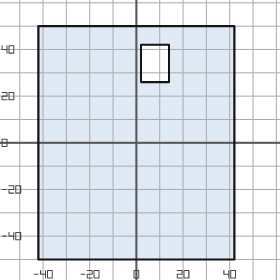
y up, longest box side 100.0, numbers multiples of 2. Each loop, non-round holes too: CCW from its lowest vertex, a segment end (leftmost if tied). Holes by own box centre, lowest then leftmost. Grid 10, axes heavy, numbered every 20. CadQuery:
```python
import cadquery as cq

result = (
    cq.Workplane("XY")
    .moveTo(-42.0, -50.0)
    .lineTo(42.0, -50.0)
    .lineTo(42.0, 50.0)
    .lineTo(-42.0, 50.0)
    .close()
    .moveTo(2.0, 26.0)
    .lineTo(14.0, 26.0)
    .lineTo(14.0, 42.0)
    .lineTo(2.0, 42.0)
    .close()
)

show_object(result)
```